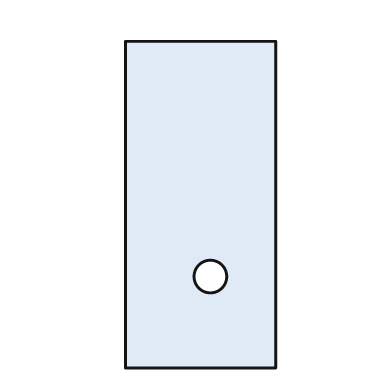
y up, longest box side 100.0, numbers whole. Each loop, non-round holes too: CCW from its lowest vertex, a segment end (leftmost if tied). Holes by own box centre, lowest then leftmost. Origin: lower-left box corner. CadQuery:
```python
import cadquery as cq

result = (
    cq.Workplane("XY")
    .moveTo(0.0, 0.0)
    .lineTo(46.0, 0.0)
    .lineTo(46.0, 100.0)
    .lineTo(0.0, 100.0)
    .close()
    .moveTo(26.0, 28.0)
    .circle(5.0)
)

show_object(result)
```